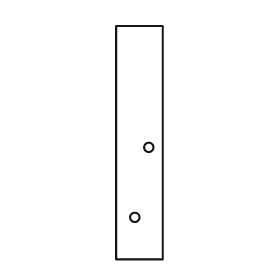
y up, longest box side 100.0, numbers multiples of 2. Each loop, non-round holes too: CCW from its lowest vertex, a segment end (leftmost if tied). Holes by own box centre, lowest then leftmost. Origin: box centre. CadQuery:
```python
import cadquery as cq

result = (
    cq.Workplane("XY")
    .moveTo(-10.0, -50.0)
    .lineTo(10.0, -50.0)
    .lineTo(10.0, 50.0)
    .lineTo(-10.0, 50.0)
    .close()
    .moveTo(-2.0, -32.0)
    .circle(2.0)
    .moveTo(4.0, -2.0)
    .circle(2.0)
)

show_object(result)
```